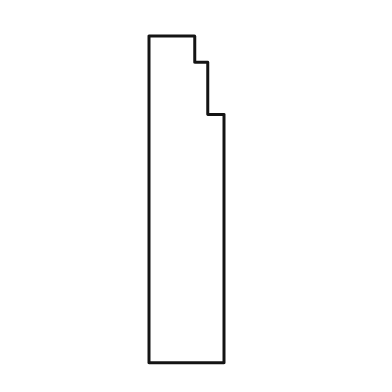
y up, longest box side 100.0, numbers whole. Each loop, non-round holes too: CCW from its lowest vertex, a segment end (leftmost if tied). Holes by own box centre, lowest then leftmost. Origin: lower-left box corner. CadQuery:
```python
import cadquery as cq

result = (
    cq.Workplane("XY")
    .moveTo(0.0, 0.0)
    .lineTo(23.0, 0.0)
    .lineTo(23.0, 76.0)
    .lineTo(18.0, 76.0)
    .lineTo(18.0, 92.0)
    .lineTo(14.0, 92.0)
    .lineTo(14.0, 100.0)
    .lineTo(0.0, 100.0)
    .close()
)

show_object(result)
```